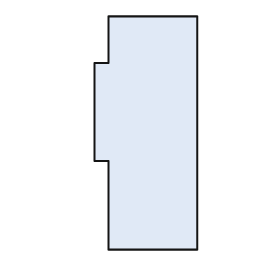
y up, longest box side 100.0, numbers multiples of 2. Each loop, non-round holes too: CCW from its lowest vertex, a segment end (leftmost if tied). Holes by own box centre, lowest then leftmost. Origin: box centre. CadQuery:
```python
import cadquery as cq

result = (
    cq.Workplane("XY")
    .moveTo(-16.0, -50.0)
    .lineTo(22.0, -50.0)
    .lineTo(22.0, 50.0)
    .lineTo(-16.0, 50.0)
    .lineTo(-16.0, 30.0)
    .lineTo(-22.0, 30.0)
    .lineTo(-22.0, -12.0)
    .lineTo(-16.0, -12.0)
    .close()
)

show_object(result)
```